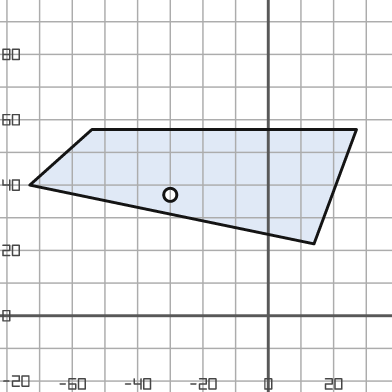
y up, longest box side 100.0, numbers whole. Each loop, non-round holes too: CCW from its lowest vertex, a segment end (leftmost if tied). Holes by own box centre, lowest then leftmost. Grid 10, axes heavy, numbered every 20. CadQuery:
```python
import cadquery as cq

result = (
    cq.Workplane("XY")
    .moveTo(14.0, 22.0)
    .lineTo(27.0, 57.0)
    .lineTo(-54.0, 57.0)
    .lineTo(-73.0, 40.0)
    .close()
    .moveTo(-30.0, 37.0)
    .circle(2.0)
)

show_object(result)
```